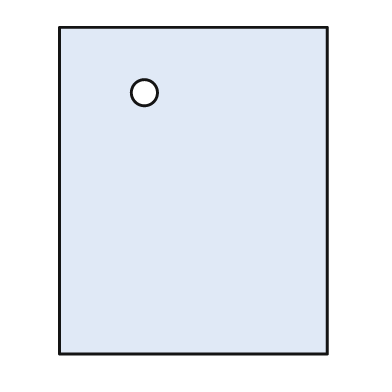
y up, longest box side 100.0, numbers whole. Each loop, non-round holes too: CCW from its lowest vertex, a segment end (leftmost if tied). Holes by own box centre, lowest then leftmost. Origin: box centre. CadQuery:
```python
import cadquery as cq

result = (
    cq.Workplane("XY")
    .moveTo(-41.0, -50.0)
    .lineTo(41.0, -50.0)
    .lineTo(41.0, 50.0)
    .lineTo(-41.0, 50.0)
    .close()
    .moveTo(-15.0, 30.0)
    .circle(4.0)
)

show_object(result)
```